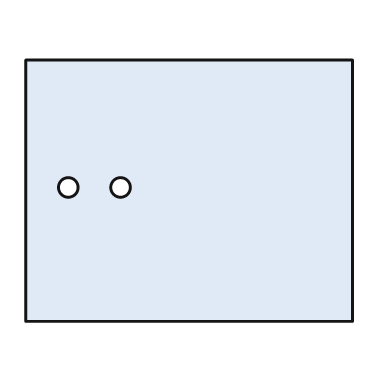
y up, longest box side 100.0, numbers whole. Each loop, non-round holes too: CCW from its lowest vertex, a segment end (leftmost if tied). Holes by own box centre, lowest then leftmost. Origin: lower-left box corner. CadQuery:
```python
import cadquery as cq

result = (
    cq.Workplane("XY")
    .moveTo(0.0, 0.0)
    .lineTo(100.0, 0.0)
    .lineTo(100.0, 80.0)
    .lineTo(0.0, 80.0)
    .close()
    .moveTo(13.0, 41.0)
    .circle(3.0)
    .moveTo(29.0, 41.0)
    .circle(3.0)
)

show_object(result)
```